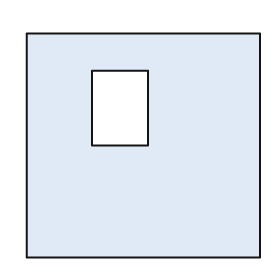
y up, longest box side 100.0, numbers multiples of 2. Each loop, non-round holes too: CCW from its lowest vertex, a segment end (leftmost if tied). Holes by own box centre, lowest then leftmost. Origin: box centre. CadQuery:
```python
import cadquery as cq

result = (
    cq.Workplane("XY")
    .moveTo(-50.0, -48.0)
    .lineTo(50.0, -48.0)
    .lineTo(50.0, 48.0)
    .lineTo(-50.0, 48.0)
    .close()
    .moveTo(-22.0, 0.0)
    .lineTo(2.0, 0.0)
    .lineTo(2.0, 32.0)
    .lineTo(-22.0, 32.0)
    .close()
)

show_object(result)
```